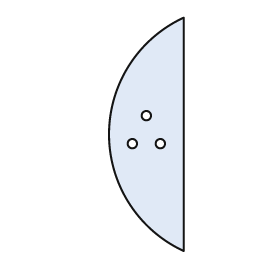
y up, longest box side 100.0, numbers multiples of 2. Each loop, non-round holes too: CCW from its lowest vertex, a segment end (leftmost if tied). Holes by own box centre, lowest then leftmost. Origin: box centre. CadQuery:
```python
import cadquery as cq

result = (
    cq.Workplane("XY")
    .moveTo(16.0, -50.0)
    .lineTo(16.0, 50.0)
    .threePointArc((-16.0, 0.0), (16.0, -50.0))
    .close()
    .moveTo(-6.0, -4.0)
    .circle(2.0)
    .moveTo(6.0, -4.0)
    .circle(2.0)
    .moveTo(0.0, 8.0)
    .circle(2.0)
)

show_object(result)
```